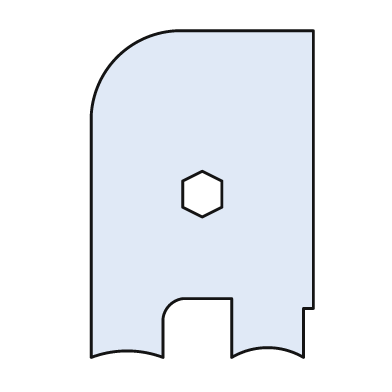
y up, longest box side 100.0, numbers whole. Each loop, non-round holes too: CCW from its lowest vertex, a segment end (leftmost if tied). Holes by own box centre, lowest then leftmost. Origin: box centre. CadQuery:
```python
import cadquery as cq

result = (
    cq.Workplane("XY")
    .moveTo(-34.0, -50.0)
    .threePointArc((-23.0, -48.0), (-12.0, -50.0))
    .lineTo(-12.0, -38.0)
    .threePointArc((-10.0, -34.0), (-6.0, -32.0))
    .lineTo(9.0, -32.0)
    .lineTo(9.0, -50.0)
    .threePointArc((20.0, -47.0), (31.0, -50.0))
    .lineTo(31.0, -35.0)
    .lineTo(34.0, -35.0)
    .lineTo(34.0, 50.0)
    .lineTo(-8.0, 50.0)
    .threePointArc((-26.0, 42.0), (-34.0, 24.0))
    .close()
    .moveTo(0.0, -7.0)
    .lineTo(6.0, -4.0)
    .lineTo(6.0, 4.0)
    .lineTo(0.0, 7.0)
    .lineTo(-6.0, 4.0)
    .lineTo(-6.0, -4.0)
    .close()
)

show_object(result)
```